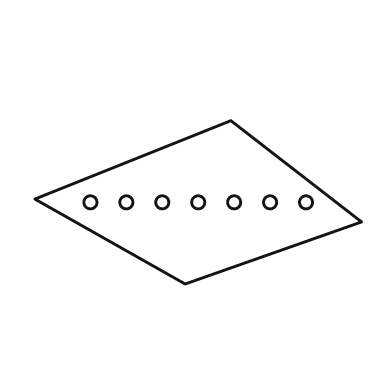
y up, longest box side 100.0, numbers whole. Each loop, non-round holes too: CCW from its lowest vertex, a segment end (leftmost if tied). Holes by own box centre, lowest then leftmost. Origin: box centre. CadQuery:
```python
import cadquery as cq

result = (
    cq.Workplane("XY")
    .moveTo(-4.0, -25.0)
    .lineTo(50.0, -6.0)
    .lineTo(10.0, 25.0)
    .lineTo(-50.0, 1.0)
    .close()
    .moveTo(-33.0, 0.0)
    .circle(2.0)
    .moveTo(-22.0, 0.0)
    .circle(2.0)
    .moveTo(-11.0, 0.0)
    .circle(2.0)
    .moveTo(0.0, 0.0)
    .circle(2.0)
    .moveTo(11.0, 0.0)
    .circle(2.0)
    .moveTo(22.0, 0.0)
    .circle(2.0)
    .moveTo(33.0, 0.0)
    .circle(2.0)
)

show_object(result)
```